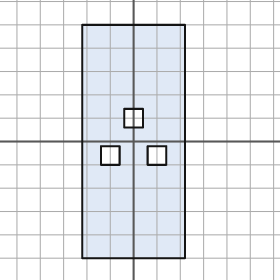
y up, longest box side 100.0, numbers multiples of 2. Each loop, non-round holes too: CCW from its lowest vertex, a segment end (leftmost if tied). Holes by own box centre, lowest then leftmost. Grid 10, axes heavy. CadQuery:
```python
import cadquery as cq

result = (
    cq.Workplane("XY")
    .moveTo(-22.0, -50.0)
    .lineTo(22.0, -50.0)
    .lineTo(22.0, 50.0)
    .lineTo(-22.0, 50.0)
    .close()
    .moveTo(-14.0, -10.0)
    .lineTo(-6.0, -10.0)
    .lineTo(-6.0, -2.0)
    .lineTo(-14.0, -2.0)
    .close()
    .moveTo(6.0, -10.0)
    .lineTo(14.0, -10.0)
    .lineTo(14.0, -2.0)
    .lineTo(6.0, -2.0)
    .close()
    .moveTo(-4.0, 6.0)
    .lineTo(4.0, 6.0)
    .lineTo(4.0, 14.0)
    .lineTo(-4.0, 14.0)
    .close()
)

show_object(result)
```